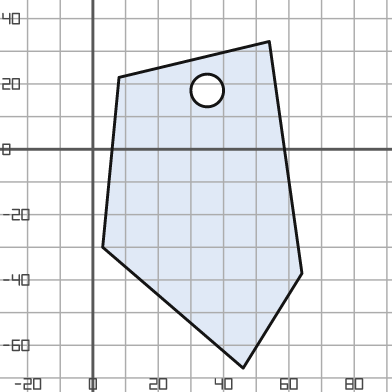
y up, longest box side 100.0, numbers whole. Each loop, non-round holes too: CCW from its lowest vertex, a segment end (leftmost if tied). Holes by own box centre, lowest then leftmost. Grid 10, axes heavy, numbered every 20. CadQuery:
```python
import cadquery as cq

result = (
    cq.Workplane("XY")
    .moveTo(46.0, -67.0)
    .lineTo(64.0, -38.0)
    .lineTo(54.0, 33.0)
    .lineTo(8.0, 22.0)
    .lineTo(3.0, -30.0)
    .close()
    .moveTo(35.0, 18.0)
    .circle(5.0)
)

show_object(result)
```